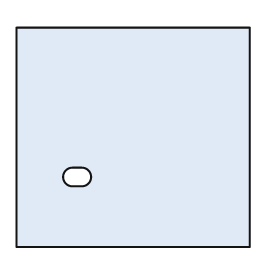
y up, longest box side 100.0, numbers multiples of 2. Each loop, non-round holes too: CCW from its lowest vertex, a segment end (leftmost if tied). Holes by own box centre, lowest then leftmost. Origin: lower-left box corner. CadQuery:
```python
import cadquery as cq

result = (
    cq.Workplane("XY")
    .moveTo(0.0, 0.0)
    .lineTo(100.0, 0.0)
    .lineTo(100.0, 94.0)
    .lineTo(0.0, 94.0)
    .close()
    .moveTo(24.0, 26.0)
    .lineTo(28.0, 26.0)
    .threePointArc((32.0, 30.0), (28.0, 34.0))
    .lineTo(24.0, 34.0)
    .threePointArc((20.0, 30.0), (24.0, 26.0))
    .close()
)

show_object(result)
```